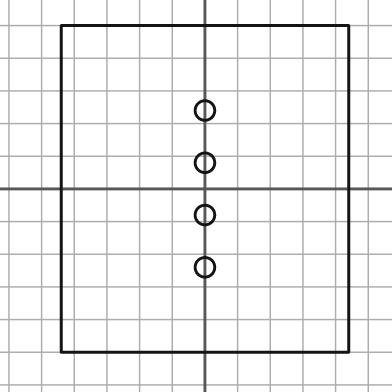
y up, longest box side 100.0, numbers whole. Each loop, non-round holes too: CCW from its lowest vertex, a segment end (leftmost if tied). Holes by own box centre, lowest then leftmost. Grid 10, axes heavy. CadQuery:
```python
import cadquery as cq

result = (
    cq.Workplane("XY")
    .moveTo(-44.0, -50.0)
    .lineTo(44.0, -50.0)
    .lineTo(44.0, 50.0)
    .lineTo(-44.0, 50.0)
    .close()
    .moveTo(0.0, -24.0)
    .circle(3.0)
    .moveTo(0.0, -8.0)
    .circle(3.0)
    .moveTo(0.0, 8.0)
    .circle(3.0)
    .moveTo(0.0, 24.0)
    .circle(3.0)
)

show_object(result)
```